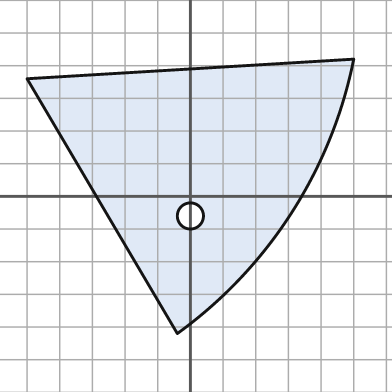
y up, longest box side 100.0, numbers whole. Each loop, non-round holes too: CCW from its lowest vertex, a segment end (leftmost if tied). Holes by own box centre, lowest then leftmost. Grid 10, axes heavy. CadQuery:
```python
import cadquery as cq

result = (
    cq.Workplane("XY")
    .moveTo(-4.0, -42.0)
    .threePointArc((31.0, -5.0), (50.0, 42.0))
    .lineTo(-50.0, 36.0)
    .close()
    .moveTo(0.0, -6.0)
    .circle(4.0)
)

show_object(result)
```